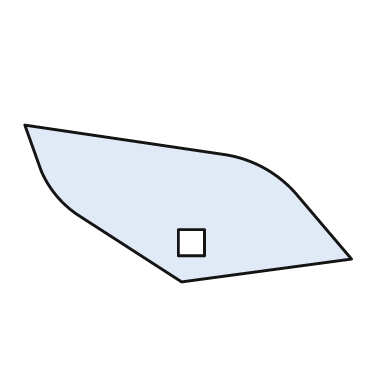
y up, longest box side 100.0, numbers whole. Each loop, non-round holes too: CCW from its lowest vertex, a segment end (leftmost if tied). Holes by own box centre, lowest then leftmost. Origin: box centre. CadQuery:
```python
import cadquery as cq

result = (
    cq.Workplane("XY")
    .moveTo(-2.0, -24.0)
    .lineTo(50.0, -17.0)
    .lineTo(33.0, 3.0)
    .threePointArc((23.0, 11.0), (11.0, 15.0))
    .lineTo(-50.0, 24.0)
    .lineTo(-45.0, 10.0)
    .threePointArc((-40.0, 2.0), (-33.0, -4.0))
    .close()
    .moveTo(-3.0, -16.0)
    .lineTo(5.0, -16.0)
    .lineTo(5.0, -8.0)
    .lineTo(-3.0, -8.0)
    .close()
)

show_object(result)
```